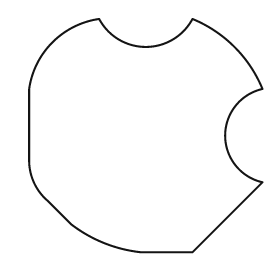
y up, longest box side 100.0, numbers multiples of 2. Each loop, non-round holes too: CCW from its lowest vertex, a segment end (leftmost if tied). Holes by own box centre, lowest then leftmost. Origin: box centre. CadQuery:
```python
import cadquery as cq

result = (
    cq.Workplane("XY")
    .moveTo(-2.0, -50.0)
    .lineTo(20.0, -50.0)
    .lineTo(50.0, -20.0)
    .threePointArc((34.0, 0.0), (50.0, 20.0))
    .threePointArc((38.0, 38.0), (20.0, 50.0))
    .threePointArc((0.0, 38.0), (-20.0, 50.0))
    .threePointArc((-40.0, 40.0), (-50.0, 20.0))
    .lineTo(-50.0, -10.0)
    .threePointArc((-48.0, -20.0), (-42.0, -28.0))
    .lineTo(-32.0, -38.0)
    .threePointArc((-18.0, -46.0), (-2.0, -50.0))
    .close()
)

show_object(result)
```